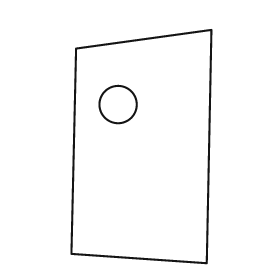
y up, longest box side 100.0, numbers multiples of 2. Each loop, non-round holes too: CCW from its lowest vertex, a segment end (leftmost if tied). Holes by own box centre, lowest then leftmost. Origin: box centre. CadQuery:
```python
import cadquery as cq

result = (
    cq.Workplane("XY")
    .moveTo(28.0, -50.0)
    .lineTo(30.0, 50.0)
    .lineTo(-28.0, 42.0)
    .lineTo(-30.0, -46.0)
    .close()
    .moveTo(-10.0, 18.0)
    .circle(8.0)
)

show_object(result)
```